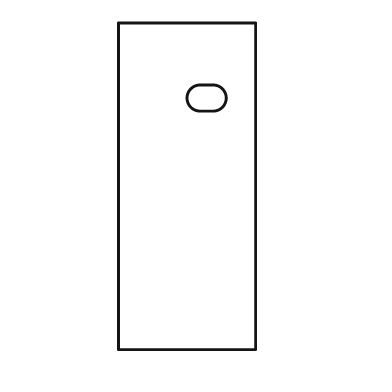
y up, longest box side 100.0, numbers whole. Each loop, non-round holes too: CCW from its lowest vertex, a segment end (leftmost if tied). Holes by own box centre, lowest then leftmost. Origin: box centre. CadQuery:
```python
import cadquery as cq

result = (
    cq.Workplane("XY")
    .moveTo(-21.0, -50.0)
    .lineTo(21.0, -50.0)
    .lineTo(21.0, 50.0)
    .lineTo(-21.0, 50.0)
    .close()
    .moveTo(4.0, 23.0)
    .lineTo(8.0, 23.0)
    .threePointArc((12.0, 27.0), (8.0, 31.0))
    .lineTo(4.0, 31.0)
    .threePointArc((0.0, 27.0), (4.0, 23.0))
    .close()
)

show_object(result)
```